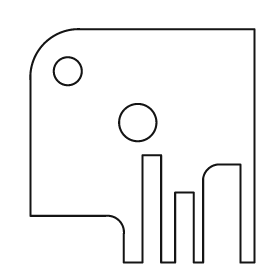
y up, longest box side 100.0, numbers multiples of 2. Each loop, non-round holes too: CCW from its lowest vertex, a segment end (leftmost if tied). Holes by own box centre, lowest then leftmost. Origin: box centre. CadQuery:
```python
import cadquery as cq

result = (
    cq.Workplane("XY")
    .moveTo(-8.0, -50.0)
    .lineTo(0.0, -50.0)
    .lineTo(0.0, -4.0)
    .lineTo(8.0, -4.0)
    .lineTo(8.0, -50.0)
    .lineTo(14.0, -50.0)
    .lineTo(14.0, -20.0)
    .lineTo(22.0, -20.0)
    .lineTo(22.0, -50.0)
    .lineTo(26.0, -50.0)
    .lineTo(26.0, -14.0)
    .threePointArc((28.0, -10.0), (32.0, -8.0))
    .lineTo(42.0, -8.0)
    .lineTo(42.0, -50.0)
    .lineTo(48.0, -50.0)
    .lineTo(48.0, 50.0)
    .lineTo(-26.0, 50.0)
    .threePointArc((-42.0, 44.0), (-48.0, 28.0))
    .lineTo(-48.0, -30.0)
    .lineTo(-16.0, -30.0)
    .threePointArc((-10.0, -32.0), (-8.0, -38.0))
    .close()
    .moveTo(-2.0, 10.0)
    .circle(8.0)
    .moveTo(-32.0, 32.0)
    .circle(6.0)
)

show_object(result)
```